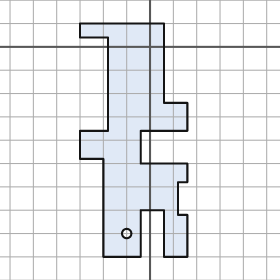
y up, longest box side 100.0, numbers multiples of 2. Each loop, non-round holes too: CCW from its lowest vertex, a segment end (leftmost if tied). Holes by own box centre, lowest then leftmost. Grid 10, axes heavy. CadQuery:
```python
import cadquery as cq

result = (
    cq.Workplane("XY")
    .moveTo(-20.0, -90.0)
    .lineTo(-4.0, -90.0)
    .lineTo(-4.0, -70.0)
    .lineTo(6.0, -70.0)
    .lineTo(6.0, -90.0)
    .lineTo(16.0, -90.0)
    .lineTo(16.0, -72.0)
    .lineTo(12.0, -72.0)
    .lineTo(12.0, -58.0)
    .lineTo(16.0, -58.0)
    .lineTo(16.0, -50.0)
    .lineTo(-4.0, -50.0)
    .lineTo(-4.0, -36.0)
    .lineTo(16.0, -36.0)
    .lineTo(16.0, -24.0)
    .lineTo(6.0, -24.0)
    .lineTo(6.0, 10.0)
    .lineTo(-30.0, 10.0)
    .lineTo(-30.0, 4.0)
    .lineTo(-18.0, 4.0)
    .lineTo(-18.0, -36.0)
    .lineTo(-30.0, -36.0)
    .lineTo(-30.0, -48.0)
    .lineTo(-20.0, -48.0)
    .close()
    .moveTo(-10.0, -80.0)
    .circle(2.0)
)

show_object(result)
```